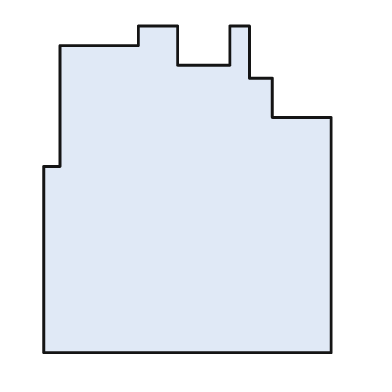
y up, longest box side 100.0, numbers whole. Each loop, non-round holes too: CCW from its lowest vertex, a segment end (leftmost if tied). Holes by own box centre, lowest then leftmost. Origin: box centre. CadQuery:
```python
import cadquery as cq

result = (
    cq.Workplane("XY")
    .moveTo(-44.0, -50.0)
    .lineTo(44.0, -50.0)
    .lineTo(44.0, 22.0)
    .lineTo(26.0, 22.0)
    .lineTo(26.0, 34.0)
    .lineTo(19.0, 34.0)
    .lineTo(19.0, 50.0)
    .lineTo(13.0, 50.0)
    .lineTo(13.0, 38.0)
    .lineTo(-3.0, 38.0)
    .lineTo(-3.0, 50.0)
    .lineTo(-15.0, 50.0)
    .lineTo(-15.0, 44.0)
    .lineTo(-39.0, 44.0)
    .lineTo(-39.0, 7.0)
    .lineTo(-44.0, 7.0)
    .close()
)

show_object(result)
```